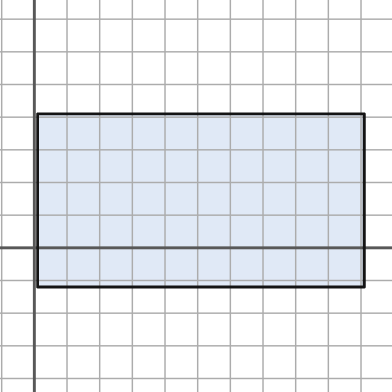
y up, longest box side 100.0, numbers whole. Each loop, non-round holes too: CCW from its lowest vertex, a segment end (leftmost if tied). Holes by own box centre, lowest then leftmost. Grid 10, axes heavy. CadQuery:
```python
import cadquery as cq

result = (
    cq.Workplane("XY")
    .moveTo(1.0, -12.0)
    .lineTo(101.0, -12.0)
    .lineTo(101.0, 41.0)
    .lineTo(1.0, 41.0)
    .close()
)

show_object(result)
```